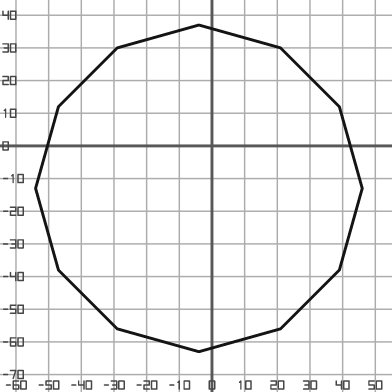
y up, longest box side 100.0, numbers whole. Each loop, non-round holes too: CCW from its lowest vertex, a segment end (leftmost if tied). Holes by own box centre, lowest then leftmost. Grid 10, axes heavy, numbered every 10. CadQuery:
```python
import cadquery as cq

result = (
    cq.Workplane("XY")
    .moveTo(-4.0, -63.0)
    .lineTo(21.0, -56.0)
    .lineTo(39.0, -38.0)
    .lineTo(46.0, -13.0)
    .lineTo(39.0, 12.0)
    .lineTo(21.0, 30.0)
    .lineTo(-4.0, 37.0)
    .lineTo(-29.0, 30.0)
    .lineTo(-47.0, 12.0)
    .lineTo(-54.0, -13.0)
    .lineTo(-47.0, -38.0)
    .lineTo(-29.0, -56.0)
    .close()
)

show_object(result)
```